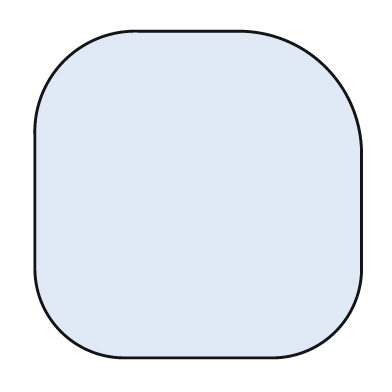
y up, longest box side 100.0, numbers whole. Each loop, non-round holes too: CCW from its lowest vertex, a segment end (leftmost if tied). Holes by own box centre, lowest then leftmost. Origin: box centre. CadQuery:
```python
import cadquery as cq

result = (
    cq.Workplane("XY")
    .moveTo(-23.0, -50.0)
    .lineTo(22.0, -50.0)
    .threePointArc((42.0, -42.0), (50.0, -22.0))
    .lineTo(50.0, 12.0)
    .threePointArc((39.0, 39.0), (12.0, 50.0))
    .lineTo(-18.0, 50.0)
    .threePointArc((-41.0, 41.0), (-50.0, 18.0))
    .lineTo(-50.0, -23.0)
    .threePointArc((-42.0, -42.0), (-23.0, -50.0))
    .close()
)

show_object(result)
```